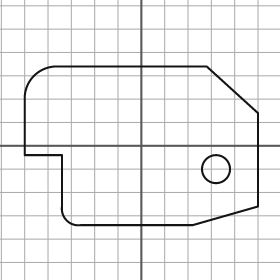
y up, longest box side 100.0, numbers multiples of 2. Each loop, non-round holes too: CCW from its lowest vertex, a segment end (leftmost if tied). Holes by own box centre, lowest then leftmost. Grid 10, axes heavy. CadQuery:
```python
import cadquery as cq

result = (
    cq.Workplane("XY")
    .moveTo(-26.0, -34.0)
    .lineTo(22.0, -34.0)
    .lineTo(50.0, -26.0)
    .lineTo(50.0, 14.0)
    .lineTo(28.0, 34.0)
    .lineTo(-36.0, 34.0)
    .threePointArc((-46.0, 30.0), (-50.0, 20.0))
    .lineTo(-50.0, -4.0)
    .lineTo(-34.0, -4.0)
    .lineTo(-34.0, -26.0)
    .threePointArc((-32.0, -32.0), (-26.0, -34.0))
    .close()
    .moveTo(32.0, -10.0)
    .circle(6.0)
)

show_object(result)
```